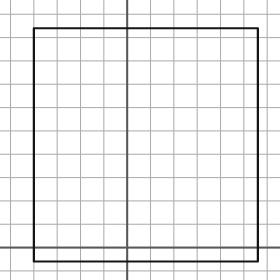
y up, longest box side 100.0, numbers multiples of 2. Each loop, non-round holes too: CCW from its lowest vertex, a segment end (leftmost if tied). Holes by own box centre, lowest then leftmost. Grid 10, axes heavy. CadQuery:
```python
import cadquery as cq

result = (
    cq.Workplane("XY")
    .moveTo(-40.0, -6.0)
    .lineTo(56.0, -6.0)
    .lineTo(56.0, 94.0)
    .lineTo(-40.0, 94.0)
    .close()
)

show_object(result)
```